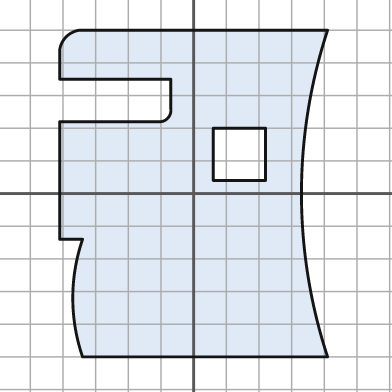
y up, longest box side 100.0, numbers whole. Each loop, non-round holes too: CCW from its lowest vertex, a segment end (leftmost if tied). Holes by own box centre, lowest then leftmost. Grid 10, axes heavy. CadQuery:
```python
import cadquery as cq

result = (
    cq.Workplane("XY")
    .moveTo(-34.0, -50.0)
    .lineTo(41.0, -50.0)
    .threePointArc((33.0, 0.0), (41.0, 50.0))
    .lineTo(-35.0, 50.0)
    .threePointArc((-39.0, 48.0), (-41.0, 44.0))
    .lineTo(-41.0, 35.0)
    .lineTo(-7.0, 35.0)
    .lineTo(-7.0, 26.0)
    .threePointArc((-8.0, 23.0), (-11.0, 22.0))
    .lineTo(-41.0, 22.0)
    .lineTo(-41.0, -14.0)
    .lineTo(-34.0, -14.0)
    .threePointArc((-37.0, -32.0), (-34.0, -50.0))
    .close()
    .moveTo(6.0, 4.0)
    .lineTo(22.0, 4.0)
    .lineTo(22.0, 20.0)
    .lineTo(6.0, 20.0)
    .close()
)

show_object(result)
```